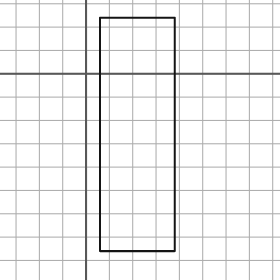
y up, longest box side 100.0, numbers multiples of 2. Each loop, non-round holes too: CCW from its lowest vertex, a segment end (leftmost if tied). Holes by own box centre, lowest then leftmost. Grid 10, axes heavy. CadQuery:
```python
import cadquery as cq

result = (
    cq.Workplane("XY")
    .moveTo(6.0, -76.0)
    .lineTo(38.0, -76.0)
    .lineTo(38.0, 24.0)
    .lineTo(6.0, 24.0)
    .close()
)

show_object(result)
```